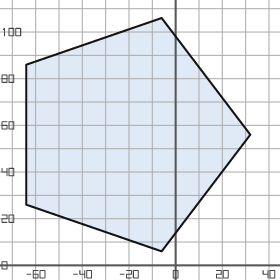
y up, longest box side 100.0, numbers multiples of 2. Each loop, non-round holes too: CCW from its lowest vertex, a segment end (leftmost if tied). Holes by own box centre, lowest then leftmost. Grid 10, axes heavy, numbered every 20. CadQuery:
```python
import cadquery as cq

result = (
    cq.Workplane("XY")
    .moveTo(-6.0, 6.0)
    .lineTo(32.0, 56.0)
    .lineTo(-6.0, 106.0)
    .lineTo(-64.0, 86.0)
    .lineTo(-64.0, 26.0)
    .close()
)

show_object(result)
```